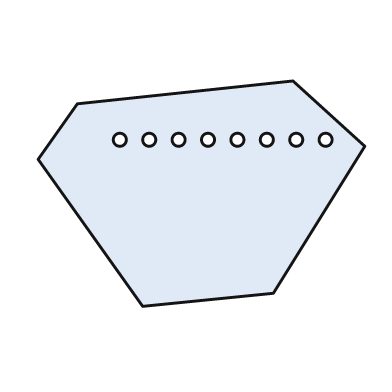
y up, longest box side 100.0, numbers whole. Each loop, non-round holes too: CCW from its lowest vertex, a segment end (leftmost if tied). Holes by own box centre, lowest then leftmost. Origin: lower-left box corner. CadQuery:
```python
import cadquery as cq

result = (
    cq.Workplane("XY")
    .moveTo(32.0, 0.0)
    .lineTo(72.0, 4.0)
    .lineTo(100.0, 49.0)
    .lineTo(78.0, 69.0)
    .lineTo(12.0, 62.0)
    .lineTo(0.0, 45.0)
    .close()
    .moveTo(25.0, 51.0)
    .circle(2.0)
    .moveTo(34.0, 51.0)
    .circle(2.0)
    .moveTo(43.0, 51.0)
    .circle(2.0)
    .moveTo(52.0, 51.0)
    .circle(2.0)
    .moveTo(61.0, 51.0)
    .circle(2.0)
    .moveTo(70.0, 51.0)
    .circle(2.0)
    .moveTo(79.0, 51.0)
    .circle(2.0)
    .moveTo(88.0, 51.0)
    .circle(2.0)
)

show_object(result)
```